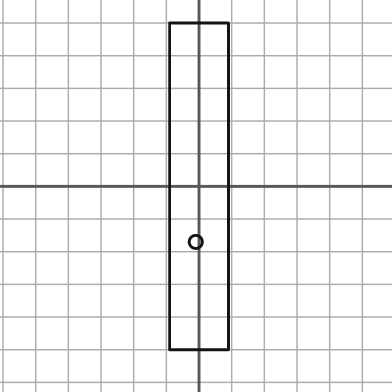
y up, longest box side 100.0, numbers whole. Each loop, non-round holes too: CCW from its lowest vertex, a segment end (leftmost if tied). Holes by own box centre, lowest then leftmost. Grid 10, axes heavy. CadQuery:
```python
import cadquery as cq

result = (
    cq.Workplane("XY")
    .moveTo(-9.0, -50.0)
    .lineTo(9.0, -50.0)
    .lineTo(9.0, 50.0)
    .lineTo(-9.0, 50.0)
    .close()
    .moveTo(-1.0, -17.0)
    .circle(2.0)
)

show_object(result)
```